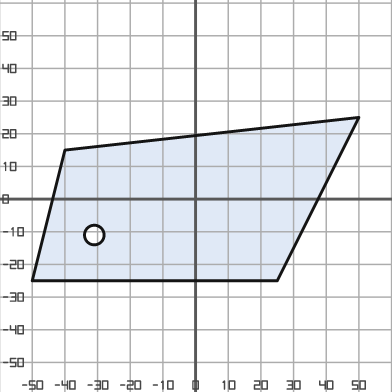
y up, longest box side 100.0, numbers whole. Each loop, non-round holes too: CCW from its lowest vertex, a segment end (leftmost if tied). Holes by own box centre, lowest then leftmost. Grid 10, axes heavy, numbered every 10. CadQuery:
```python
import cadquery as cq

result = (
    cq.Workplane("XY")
    .moveTo(-50.0, -25.0)
    .lineTo(25.0, -25.0)
    .lineTo(50.0, 25.0)
    .lineTo(-40.0, 15.0)
    .close()
    .moveTo(-31.0, -11.0)
    .circle(3.0)
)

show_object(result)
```